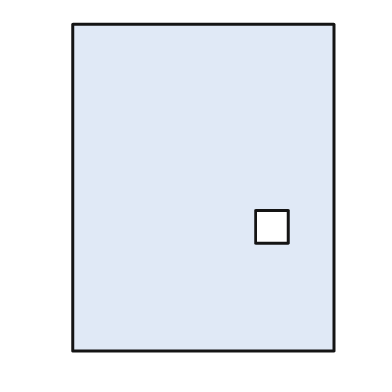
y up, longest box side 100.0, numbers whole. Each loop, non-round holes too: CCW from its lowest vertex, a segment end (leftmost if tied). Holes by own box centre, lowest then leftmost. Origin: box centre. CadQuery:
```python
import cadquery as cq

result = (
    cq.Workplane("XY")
    .moveTo(-40.0, -50.0)
    .lineTo(40.0, -50.0)
    .lineTo(40.0, 50.0)
    .lineTo(-40.0, 50.0)
    .close()
    .moveTo(16.0, -17.0)
    .lineTo(26.0, -17.0)
    .lineTo(26.0, -7.0)
    .lineTo(16.0, -7.0)
    .close()
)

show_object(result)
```